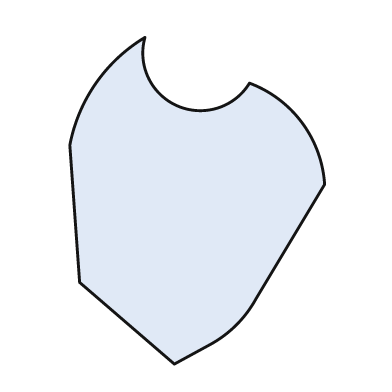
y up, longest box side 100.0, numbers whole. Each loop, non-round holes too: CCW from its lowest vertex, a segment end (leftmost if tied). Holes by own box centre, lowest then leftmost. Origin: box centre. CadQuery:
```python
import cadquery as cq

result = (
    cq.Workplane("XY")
    .moveTo(-7.0, -50.0)
    .lineTo(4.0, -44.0)
    .threePointArc((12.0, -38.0), (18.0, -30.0))
    .lineTo(39.0, 5.0)
    .threePointArc((32.0, 24.0), (16.0, 36.0))
    .threePointArc((-6.0, 29.0), (-16.0, 50.0))
    .threePointArc((-31.0, 36.0), (-39.0, 17.0))
    .lineTo(-36.0, -25.0)
    .close()
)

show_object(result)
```